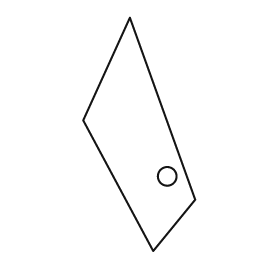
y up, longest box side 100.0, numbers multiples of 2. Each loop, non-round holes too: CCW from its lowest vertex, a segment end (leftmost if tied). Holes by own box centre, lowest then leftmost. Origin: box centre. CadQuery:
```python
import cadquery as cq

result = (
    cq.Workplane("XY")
    .moveTo(6.0, -50.0)
    .lineTo(24.0, -28.0)
    .lineTo(-4.0, 50.0)
    .lineTo(-24.0, 6.0)
    .close()
    .moveTo(12.0, -18.0)
    .circle(4.0)
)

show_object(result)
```